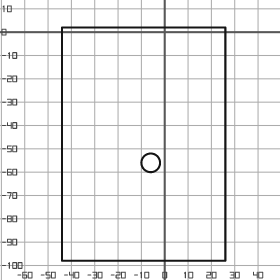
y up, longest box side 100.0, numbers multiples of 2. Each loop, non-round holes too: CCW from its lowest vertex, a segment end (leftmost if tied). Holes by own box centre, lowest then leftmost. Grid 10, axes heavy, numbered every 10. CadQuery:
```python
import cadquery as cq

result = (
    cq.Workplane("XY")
    .moveTo(-44.0, -98.0)
    .lineTo(26.0, -98.0)
    .lineTo(26.0, 2.0)
    .lineTo(-44.0, 2.0)
    .close()
    .moveTo(-6.0, -56.0)
    .circle(4.0)
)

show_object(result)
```